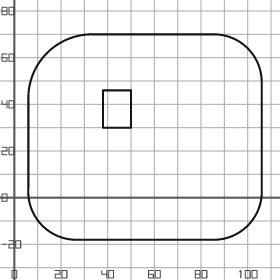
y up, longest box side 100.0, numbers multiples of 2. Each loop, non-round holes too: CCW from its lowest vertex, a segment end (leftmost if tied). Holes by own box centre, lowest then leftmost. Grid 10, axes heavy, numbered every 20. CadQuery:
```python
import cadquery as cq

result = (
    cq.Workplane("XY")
    .moveTo(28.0, -18.0)
    .lineTo(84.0, -18.0)
    .threePointArc((100.0, -12.0), (106.0, 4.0))
    .lineTo(106.0, 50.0)
    .threePointArc((100.0, 64.0), (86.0, 70.0))
    .lineTo(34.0, 70.0)
    .threePointArc((14.0, 62.0), (6.0, 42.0))
    .lineTo(6.0, 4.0)
    .threePointArc((12.0, -12.0), (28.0, -18.0))
    .close()
    .moveTo(38.0, 30.0)
    .lineTo(50.0, 30.0)
    .lineTo(50.0, 46.0)
    .lineTo(38.0, 46.0)
    .close()
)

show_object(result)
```